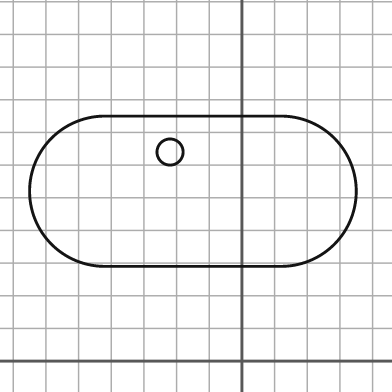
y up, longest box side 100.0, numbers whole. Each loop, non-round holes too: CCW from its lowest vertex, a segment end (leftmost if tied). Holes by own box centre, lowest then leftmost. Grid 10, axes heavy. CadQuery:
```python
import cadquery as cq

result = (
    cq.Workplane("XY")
    .moveTo(-42.0, 29.0)
    .lineTo(12.0, 29.0)
    .threePointArc((35.0, 52.0), (12.0, 75.0))
    .lineTo(-42.0, 75.0)
    .threePointArc((-65.0, 52.0), (-42.0, 29.0))
    .close()
    .moveTo(-22.0, 64.0)
    .circle(4.0)
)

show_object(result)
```